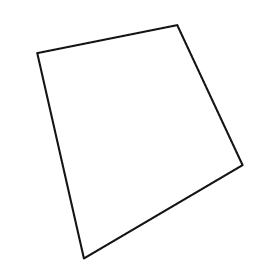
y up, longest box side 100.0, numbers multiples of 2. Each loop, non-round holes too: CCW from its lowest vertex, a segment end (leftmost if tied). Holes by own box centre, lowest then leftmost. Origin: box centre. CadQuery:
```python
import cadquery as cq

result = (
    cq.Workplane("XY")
    .moveTo(-24.0, -50.0)
    .lineTo(44.0, -10.0)
    .lineTo(16.0, 50.0)
    .lineTo(-44.0, 38.0)
    .close()
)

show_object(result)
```